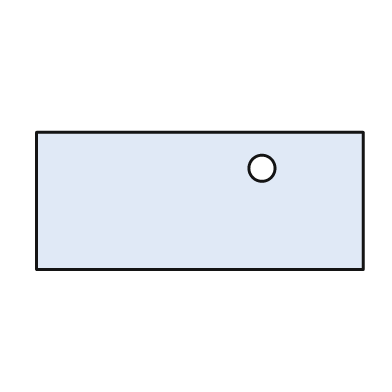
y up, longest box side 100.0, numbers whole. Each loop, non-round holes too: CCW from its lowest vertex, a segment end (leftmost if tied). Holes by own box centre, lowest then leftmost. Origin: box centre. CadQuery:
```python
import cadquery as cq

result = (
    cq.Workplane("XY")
    .moveTo(-50.0, -21.0)
    .lineTo(50.0, -21.0)
    .lineTo(50.0, 21.0)
    .lineTo(-50.0, 21.0)
    .close()
    .moveTo(19.0, 10.0)
    .circle(4.0)
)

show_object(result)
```